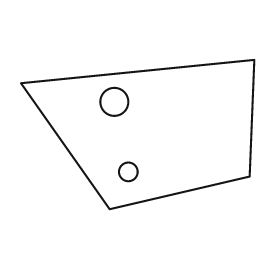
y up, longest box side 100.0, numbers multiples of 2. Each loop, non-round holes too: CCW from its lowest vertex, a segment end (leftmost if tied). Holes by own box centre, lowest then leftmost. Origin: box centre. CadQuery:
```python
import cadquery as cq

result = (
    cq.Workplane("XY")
    .moveTo(-12.0, -32.0)
    .lineTo(48.0, -18.0)
    .lineTo(50.0, 32.0)
    .lineTo(-50.0, 22.0)
    .close()
    .moveTo(-4.0, -16.0)
    .circle(4.0)
    .moveTo(-10.0, 14.0)
    .circle(6.0)
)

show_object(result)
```